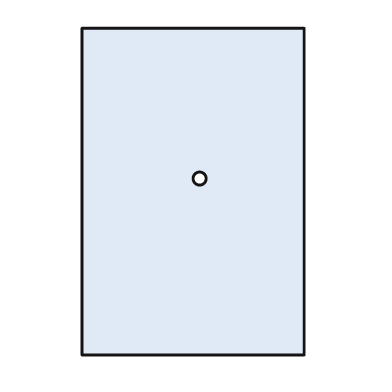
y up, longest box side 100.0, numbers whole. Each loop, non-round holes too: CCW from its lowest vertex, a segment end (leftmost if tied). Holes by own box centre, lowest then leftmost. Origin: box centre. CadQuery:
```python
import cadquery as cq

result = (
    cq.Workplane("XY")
    .moveTo(-34.0, -50.0)
    .lineTo(34.0, -50.0)
    .lineTo(34.0, 50.0)
    .lineTo(-34.0, 50.0)
    .close()
    .moveTo(2.0, 4.0)
    .circle(2.0)
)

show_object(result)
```